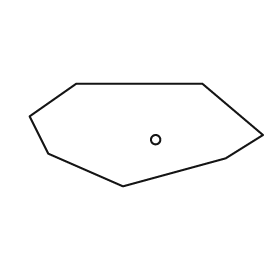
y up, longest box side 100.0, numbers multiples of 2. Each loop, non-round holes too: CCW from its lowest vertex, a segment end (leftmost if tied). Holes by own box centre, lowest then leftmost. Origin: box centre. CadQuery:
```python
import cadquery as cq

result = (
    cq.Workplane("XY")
    .moveTo(-10.0, -22.0)
    .lineTo(34.0, -10.0)
    .lineTo(50.0, 0.0)
    .lineTo(24.0, 22.0)
    .lineTo(-30.0, 22.0)
    .lineTo(-50.0, 8.0)
    .lineTo(-42.0, -8.0)
    .close()
    .moveTo(4.0, -2.0)
    .circle(2.0)
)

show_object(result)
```